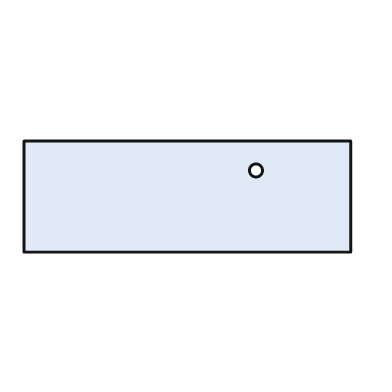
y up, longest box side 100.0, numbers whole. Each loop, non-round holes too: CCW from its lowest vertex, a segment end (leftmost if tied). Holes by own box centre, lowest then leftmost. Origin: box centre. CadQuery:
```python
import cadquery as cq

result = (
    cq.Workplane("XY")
    .moveTo(-50.0, -17.0)
    .lineTo(50.0, -17.0)
    .lineTo(50.0, 17.0)
    .lineTo(-50.0, 17.0)
    .close()
    .moveTo(21.0, 8.0)
    .circle(2.0)
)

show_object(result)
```